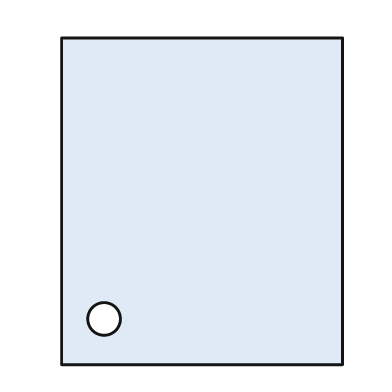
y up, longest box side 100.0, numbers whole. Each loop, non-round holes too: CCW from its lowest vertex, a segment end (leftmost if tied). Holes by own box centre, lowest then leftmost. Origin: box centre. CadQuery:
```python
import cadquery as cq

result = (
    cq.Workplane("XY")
    .moveTo(-43.0, -50.0)
    .lineTo(43.0, -50.0)
    .lineTo(43.0, 50.0)
    .lineTo(-43.0, 50.0)
    .close()
    .moveTo(-30.0, -36.0)
    .circle(5.0)
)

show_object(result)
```